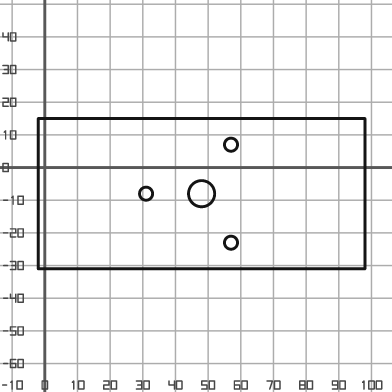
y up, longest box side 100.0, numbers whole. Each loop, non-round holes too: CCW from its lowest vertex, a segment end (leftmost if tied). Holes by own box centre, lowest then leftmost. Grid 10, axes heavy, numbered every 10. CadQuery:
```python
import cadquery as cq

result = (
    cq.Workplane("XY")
    .moveTo(-2.0, -31.0)
    .lineTo(98.0, -31.0)
    .lineTo(98.0, 15.0)
    .lineTo(-2.0, 15.0)
    .close()
    .moveTo(57.0, -23.0)
    .circle(2.0)
    .moveTo(31.0, -8.0)
    .circle(2.0)
    .moveTo(48.0, -8.0)
    .circle(4.0)
    .moveTo(57.0, 7.0)
    .circle(2.0)
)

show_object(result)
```